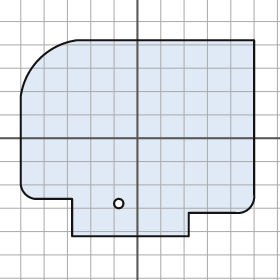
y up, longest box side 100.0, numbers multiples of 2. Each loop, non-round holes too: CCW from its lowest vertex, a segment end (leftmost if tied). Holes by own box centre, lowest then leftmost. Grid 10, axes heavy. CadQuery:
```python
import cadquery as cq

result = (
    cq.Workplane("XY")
    .moveTo(-28.0, -42.0)
    .lineTo(22.0, -42.0)
    .lineTo(22.0, -32.0)
    .lineTo(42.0, -32.0)
    .threePointArc((48.0, -30.0), (50.0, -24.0))
    .lineTo(50.0, 42.0)
    .lineTo(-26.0, 42.0)
    .threePointArc((-42.0, 34.0), (-50.0, 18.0))
    .lineTo(-50.0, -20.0)
    .threePointArc((-48.0, -24.0), (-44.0, -26.0))
    .lineTo(-28.0, -26.0)
    .close()
    .moveTo(-8.0, -28.0)
    .circle(2.0)
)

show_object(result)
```